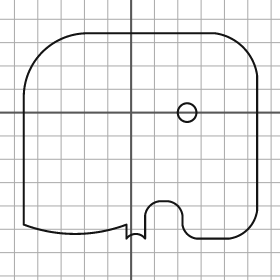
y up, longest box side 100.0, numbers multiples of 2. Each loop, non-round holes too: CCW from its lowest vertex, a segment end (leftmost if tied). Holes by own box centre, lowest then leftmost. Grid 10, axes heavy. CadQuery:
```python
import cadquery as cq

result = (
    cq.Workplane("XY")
    .moveTo(-2.0, -54.0)
    .threePointArc((2.0, -52.0), (6.0, -54.0))
    .lineTo(6.0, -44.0)
    .threePointArc((8.0, -40.0), (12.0, -38.0))
    .lineTo(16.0, -38.0)
    .threePointArc((20.0, -40.0), (22.0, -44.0))
    .lineTo(22.0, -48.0)
    .threePointArc((24.0, -52.0), (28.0, -54.0))
    .lineTo(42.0, -54.0)
    .threePointArc((50.0, -50.0), (54.0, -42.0))
    .lineTo(54.0, 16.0)
    .threePointArc((48.0, 28.0), (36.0, 34.0))
    .lineTo(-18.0, 34.0)
    .threePointArc((-38.0, 26.0), (-46.0, 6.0))
    .lineTo(-46.0, -48.0)
    .threePointArc((-24.0, -52.0), (-2.0, -48.0))
    .close()
    .moveTo(24.0, 0.0)
    .circle(4.0)
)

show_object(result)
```